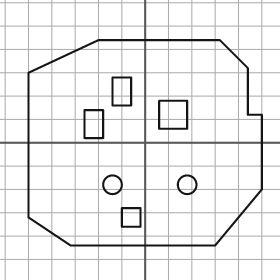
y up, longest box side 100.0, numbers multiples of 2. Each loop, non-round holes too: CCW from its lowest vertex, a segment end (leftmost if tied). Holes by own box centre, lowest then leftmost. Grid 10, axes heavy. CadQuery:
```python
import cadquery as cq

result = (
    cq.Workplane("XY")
    .moveTo(-32.0, -44.0)
    .lineTo(30.0, -44.0)
    .lineTo(50.0, -20.0)
    .lineTo(50.0, 12.0)
    .lineTo(44.0, 12.0)
    .lineTo(44.0, 32.0)
    .lineTo(32.0, 44.0)
    .lineTo(-20.0, 44.0)
    .lineTo(-50.0, 30.0)
    .lineTo(-50.0, -32.0)
    .close()
    .moveTo(-10.0, -36.0)
    .lineTo(-2.0, -36.0)
    .lineTo(-2.0, -28.0)
    .lineTo(-10.0, -28.0)
    .close()
    .moveTo(-14.0, -18.0)
    .circle(4.0)
    .moveTo(18.0, -18.0)
    .circle(4.0)
    .moveTo(-26.0, 2.0)
    .lineTo(-18.0, 2.0)
    .lineTo(-18.0, 14.0)
    .lineTo(-26.0, 14.0)
    .close()
    .moveTo(6.0, 6.0)
    .lineTo(18.0, 6.0)
    .lineTo(18.0, 18.0)
    .lineTo(6.0, 18.0)
    .close()
    .moveTo(-14.0, 16.0)
    .lineTo(-6.0, 16.0)
    .lineTo(-6.0, 28.0)
    .lineTo(-14.0, 28.0)
    .close()
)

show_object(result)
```